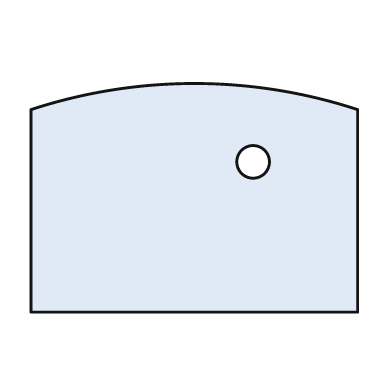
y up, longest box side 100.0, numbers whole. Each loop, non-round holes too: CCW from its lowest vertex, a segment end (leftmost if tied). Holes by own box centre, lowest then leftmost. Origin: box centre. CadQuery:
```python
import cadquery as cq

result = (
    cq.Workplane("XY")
    .moveTo(-50.0, -35.0)
    .lineTo(50.0, -35.0)
    .lineTo(50.0, 27.0)
    .threePointArc((0.0, 35.0), (-50.0, 27.0))
    .close()
    .moveTo(18.0, 11.0)
    .circle(5.0)
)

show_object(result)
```